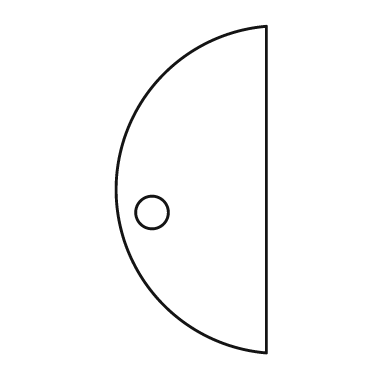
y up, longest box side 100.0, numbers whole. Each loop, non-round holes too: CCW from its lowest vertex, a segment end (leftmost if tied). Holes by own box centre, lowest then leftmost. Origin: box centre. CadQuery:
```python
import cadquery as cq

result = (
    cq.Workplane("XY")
    .moveTo(23.0, -50.0)
    .lineTo(23.0, 50.0)
    .threePointArc((-23.0, 0.0), (23.0, -50.0))
    .close()
    .moveTo(-12.0, -7.0)
    .circle(5.0)
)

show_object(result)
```